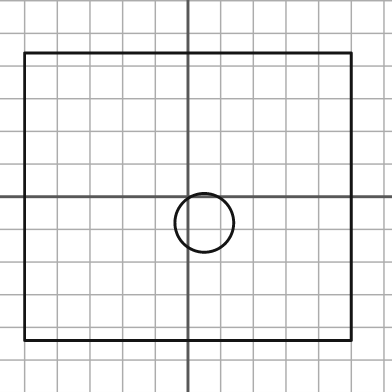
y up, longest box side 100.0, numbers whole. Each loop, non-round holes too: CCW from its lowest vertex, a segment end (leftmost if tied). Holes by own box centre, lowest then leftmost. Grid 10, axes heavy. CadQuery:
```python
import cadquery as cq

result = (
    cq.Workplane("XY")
    .moveTo(-50.0, -44.0)
    .lineTo(50.0, -44.0)
    .lineTo(50.0, 44.0)
    .lineTo(-50.0, 44.0)
    .close()
    .moveTo(5.0, -8.0)
    .circle(9.0)
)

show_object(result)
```